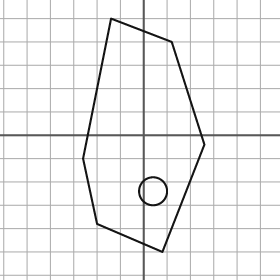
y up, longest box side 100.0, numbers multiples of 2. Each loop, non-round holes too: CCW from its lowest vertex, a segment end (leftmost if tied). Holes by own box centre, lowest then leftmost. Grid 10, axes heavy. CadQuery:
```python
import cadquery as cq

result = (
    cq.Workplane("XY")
    .moveTo(8.0, -50.0)
    .lineTo(26.0, -4.0)
    .lineTo(12.0, 40.0)
    .lineTo(-14.0, 50.0)
    .lineTo(-26.0, -10.0)
    .lineTo(-20.0, -38.0)
    .close()
    .moveTo(4.0, -24.0)
    .circle(6.0)
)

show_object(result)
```